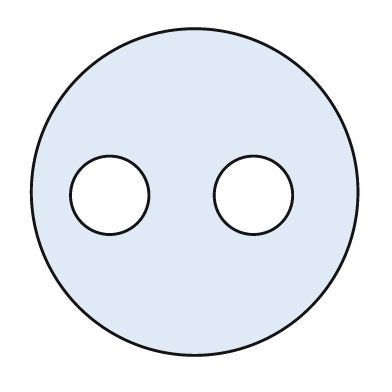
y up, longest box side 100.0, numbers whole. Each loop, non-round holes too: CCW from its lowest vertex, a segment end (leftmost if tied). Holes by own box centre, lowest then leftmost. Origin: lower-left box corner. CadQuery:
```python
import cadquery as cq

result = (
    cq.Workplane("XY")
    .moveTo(50.0, 50.0)
    .circle(50.0)
    .moveTo(24.0, 49.0)
    .circle(12.0)
    .moveTo(68.0, 49.0)
    .circle(12.0)
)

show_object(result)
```